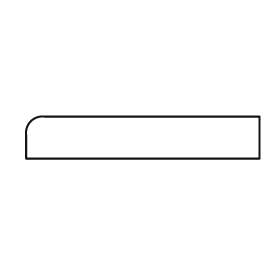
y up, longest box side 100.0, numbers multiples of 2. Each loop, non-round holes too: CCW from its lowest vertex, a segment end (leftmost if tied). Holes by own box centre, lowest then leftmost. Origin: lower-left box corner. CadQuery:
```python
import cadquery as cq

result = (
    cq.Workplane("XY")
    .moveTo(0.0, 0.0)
    .lineTo(100.0, 0.0)
    .lineTo(100.0, 18.0)
    .lineTo(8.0, 18.0)
    .threePointArc((2.0, 16.0), (0.0, 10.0))
    .close()
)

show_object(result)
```